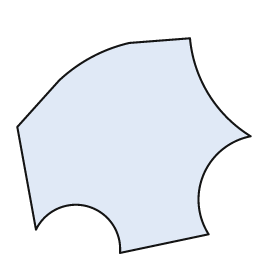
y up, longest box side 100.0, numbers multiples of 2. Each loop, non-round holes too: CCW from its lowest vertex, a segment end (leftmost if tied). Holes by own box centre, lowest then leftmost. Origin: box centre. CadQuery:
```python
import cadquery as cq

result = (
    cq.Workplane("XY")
    .moveTo(-6.0, -46.0)
    .lineTo(32.0, -38.0)
    .threePointArc((30.0, -12.0), (50.0, 4.0))
    .threePointArc((32.0, 22.0), (24.0, 46.0))
    .lineTo(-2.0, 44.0)
    .threePointArc((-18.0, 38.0), (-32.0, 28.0))
    .lineTo(-50.0, 8.0)
    .lineTo(-42.0, -36.0)
    .threePointArc((-20.0, -26.0), (-6.0, -46.0))
    .close()
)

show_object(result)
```